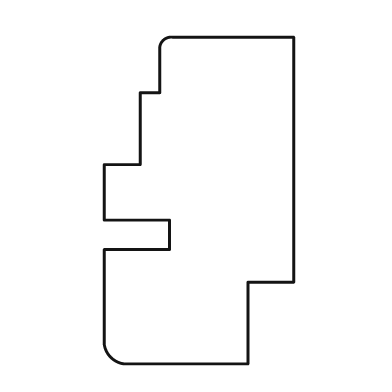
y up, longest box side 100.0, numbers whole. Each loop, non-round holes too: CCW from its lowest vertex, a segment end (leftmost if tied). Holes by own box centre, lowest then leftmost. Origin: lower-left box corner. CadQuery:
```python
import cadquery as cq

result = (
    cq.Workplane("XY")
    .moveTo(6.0, 0.0)
    .lineTo(44.0, 0.0)
    .lineTo(44.0, 25.0)
    .lineTo(58.0, 25.0)
    .lineTo(58.0, 100.0)
    .lineTo(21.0, 100.0)
    .threePointArc((18.0, 99.0), (17.0, 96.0))
    .lineTo(17.0, 83.0)
    .lineTo(11.0, 83.0)
    .lineTo(11.0, 61.0)
    .lineTo(0.0, 61.0)
    .lineTo(0.0, 44.0)
    .lineTo(20.0, 44.0)
    .lineTo(20.0, 35.0)
    .lineTo(0.0, 35.0)
    .lineTo(0.0, 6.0)
    .threePointArc((2.0, 2.0), (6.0, 0.0))
    .close()
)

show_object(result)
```